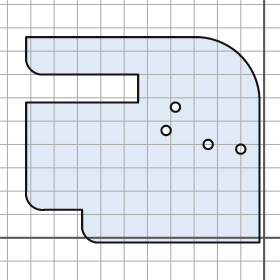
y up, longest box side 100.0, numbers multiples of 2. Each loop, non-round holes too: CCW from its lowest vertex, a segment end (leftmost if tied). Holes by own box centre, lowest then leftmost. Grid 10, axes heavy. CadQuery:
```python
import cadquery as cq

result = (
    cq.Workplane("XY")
    .moveTo(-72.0, -2.0)
    .lineTo(-2.0, -2.0)
    .lineTo(-2.0, 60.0)
    .threePointArc((-10.0, 78.0), (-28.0, 86.0))
    .lineTo(-102.0, 86.0)
    .lineTo(-102.0, 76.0)
    .threePointArc((-100.0, 72.0), (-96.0, 70.0))
    .lineTo(-54.0, 70.0)
    .lineTo(-54.0, 58.0)
    .lineTo(-102.0, 58.0)
    .lineTo(-102.0, 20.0)
    .threePointArc((-100.0, 14.0), (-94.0, 12.0))
    .lineTo(-78.0, 12.0)
    .lineTo(-78.0, 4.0)
    .threePointArc((-76.0, 0.0), (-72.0, -2.0))
    .close()
    .moveTo(-10.0, 38.0)
    .circle(2.0)
    .moveTo(-24.0, 40.0)
    .circle(2.0)
    .moveTo(-42.0, 46.0)
    .circle(2.0)
    .moveTo(-38.0, 56.0)
    .circle(2.0)
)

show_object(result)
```